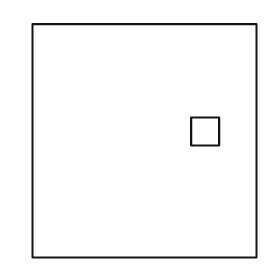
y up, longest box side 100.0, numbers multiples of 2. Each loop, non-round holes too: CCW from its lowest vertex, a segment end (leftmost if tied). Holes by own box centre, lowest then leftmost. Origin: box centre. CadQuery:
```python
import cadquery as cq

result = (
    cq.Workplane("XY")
    .moveTo(-48.0, -50.0)
    .lineTo(48.0, -50.0)
    .lineTo(48.0, 50.0)
    .lineTo(-48.0, 50.0)
    .close()
    .moveTo(20.0, -2.0)
    .lineTo(32.0, -2.0)
    .lineTo(32.0, 10.0)
    .lineTo(20.0, 10.0)
    .close()
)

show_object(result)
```